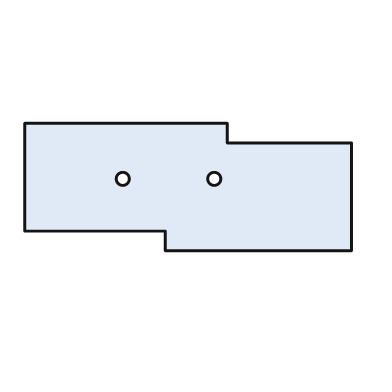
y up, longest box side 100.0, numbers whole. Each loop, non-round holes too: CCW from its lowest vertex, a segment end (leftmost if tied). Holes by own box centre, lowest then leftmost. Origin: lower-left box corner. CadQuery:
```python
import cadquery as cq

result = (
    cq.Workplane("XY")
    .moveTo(43.0, 0.0)
    .lineTo(100.0, 0.0)
    .lineTo(100.0, 33.0)
    .lineTo(62.0, 33.0)
    .lineTo(62.0, 39.0)
    .lineTo(0.0, 39.0)
    .lineTo(0.0, 6.0)
    .lineTo(43.0, 6.0)
    .close()
    .moveTo(30.0, 22.0)
    .circle(2.0)
    .moveTo(58.0, 22.0)
    .circle(2.0)
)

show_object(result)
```